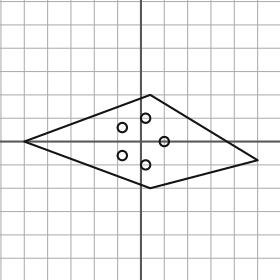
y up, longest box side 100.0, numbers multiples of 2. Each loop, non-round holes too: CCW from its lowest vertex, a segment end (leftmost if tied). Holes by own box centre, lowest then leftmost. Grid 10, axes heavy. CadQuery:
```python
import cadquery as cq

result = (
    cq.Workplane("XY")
    .moveTo(4.0, -20.0)
    .lineTo(50.0, -8.0)
    .lineTo(4.0, 20.0)
    .lineTo(-50.0, 0.0)
    .close()
    .moveTo(2.0, -10.0)
    .circle(2.0)
    .moveTo(-8.0, -6.0)
    .circle(2.0)
    .moveTo(10.0, 0.0)
    .circle(2.0)
    .moveTo(-8.0, 6.0)
    .circle(2.0)
    .moveTo(2.0, 10.0)
    .circle(2.0)
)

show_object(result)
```